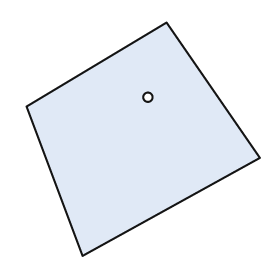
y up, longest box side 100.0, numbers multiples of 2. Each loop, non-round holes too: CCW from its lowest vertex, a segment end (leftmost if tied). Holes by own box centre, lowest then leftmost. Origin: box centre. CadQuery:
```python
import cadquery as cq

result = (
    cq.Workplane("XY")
    .moveTo(-26.0, -50.0)
    .lineTo(50.0, -8.0)
    .lineTo(10.0, 50.0)
    .lineTo(-50.0, 14.0)
    .close()
    .moveTo(2.0, 18.0)
    .circle(2.0)
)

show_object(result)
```